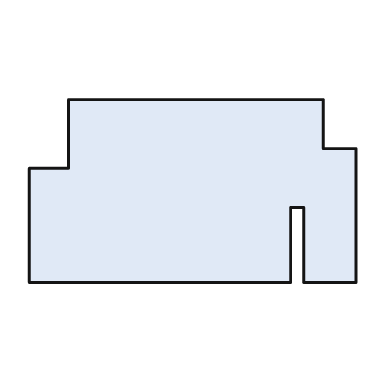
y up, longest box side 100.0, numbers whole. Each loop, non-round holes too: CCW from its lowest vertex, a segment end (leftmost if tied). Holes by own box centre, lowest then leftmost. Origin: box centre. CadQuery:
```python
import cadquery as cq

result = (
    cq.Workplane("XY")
    .moveTo(-50.0, -28.0)
    .lineTo(30.0, -28.0)
    .lineTo(30.0, -5.0)
    .lineTo(34.0, -5.0)
    .lineTo(34.0, -28.0)
    .lineTo(50.0, -28.0)
    .lineTo(50.0, 13.0)
    .lineTo(40.0, 13.0)
    .lineTo(40.0, 28.0)
    .lineTo(-38.0, 28.0)
    .lineTo(-38.0, 7.0)
    .lineTo(-50.0, 7.0)
    .close()
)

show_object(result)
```